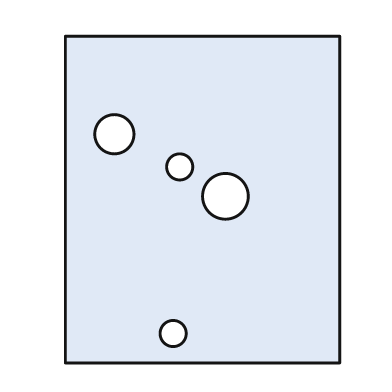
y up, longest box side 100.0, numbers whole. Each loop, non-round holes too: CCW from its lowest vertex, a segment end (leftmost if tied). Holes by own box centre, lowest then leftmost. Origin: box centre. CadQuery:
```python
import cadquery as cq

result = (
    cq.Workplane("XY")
    .moveTo(-42.0, -50.0)
    .lineTo(42.0, -50.0)
    .lineTo(42.0, 50.0)
    .lineTo(-42.0, 50.0)
    .close()
    .moveTo(-9.0, -41.0)
    .circle(4.0)
    .moveTo(7.0, 1.0)
    .circle(7.0)
    .moveTo(-7.0, 10.0)
    .circle(4.0)
    .moveTo(-27.0, 20.0)
    .circle(6.0)
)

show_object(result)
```